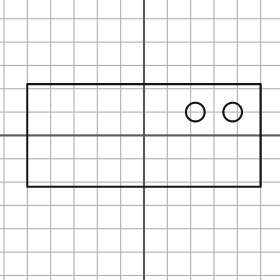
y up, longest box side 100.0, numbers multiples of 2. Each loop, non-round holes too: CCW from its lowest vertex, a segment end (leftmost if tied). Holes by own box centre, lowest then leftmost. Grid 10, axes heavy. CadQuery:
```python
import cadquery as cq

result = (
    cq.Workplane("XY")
    .moveTo(-50.0, -22.0)
    .lineTo(50.0, -22.0)
    .lineTo(50.0, 22.0)
    .lineTo(-50.0, 22.0)
    .close()
    .moveTo(22.0, 10.0)
    .circle(4.0)
    .moveTo(38.0, 10.0)
    .circle(4.0)
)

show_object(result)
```